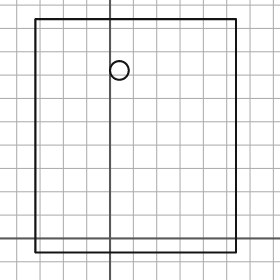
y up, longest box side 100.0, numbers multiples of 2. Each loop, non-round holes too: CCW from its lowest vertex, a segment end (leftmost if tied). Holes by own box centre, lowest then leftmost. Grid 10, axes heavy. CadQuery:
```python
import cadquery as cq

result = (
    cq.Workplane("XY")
    .moveTo(-32.0, -6.0)
    .lineTo(54.0, -6.0)
    .lineTo(54.0, 94.0)
    .lineTo(-32.0, 94.0)
    .close()
    .moveTo(4.0, 72.0)
    .circle(4.0)
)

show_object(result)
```